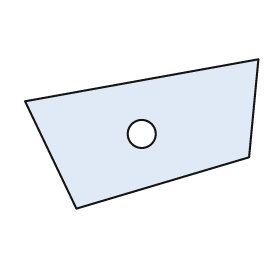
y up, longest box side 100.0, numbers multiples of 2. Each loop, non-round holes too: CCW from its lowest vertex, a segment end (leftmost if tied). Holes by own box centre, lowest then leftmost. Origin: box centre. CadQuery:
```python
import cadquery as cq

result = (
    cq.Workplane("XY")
    .moveTo(-28.0, -32.0)
    .lineTo(46.0, -10.0)
    .lineTo(50.0, 32.0)
    .lineTo(-50.0, 14.0)
    .close()
    .moveTo(0.0, 0.0)
    .circle(6.0)
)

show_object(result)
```